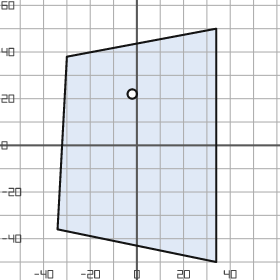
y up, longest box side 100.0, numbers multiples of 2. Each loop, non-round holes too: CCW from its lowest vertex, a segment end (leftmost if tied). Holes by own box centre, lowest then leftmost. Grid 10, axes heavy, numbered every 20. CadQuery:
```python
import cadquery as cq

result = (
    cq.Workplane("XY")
    .moveTo(34.0, -50.0)
    .lineTo(34.0, 50.0)
    .lineTo(-30.0, 38.0)
    .lineTo(-34.0, -36.0)
    .close()
    .moveTo(-2.0, 22.0)
    .circle(2.0)
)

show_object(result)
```